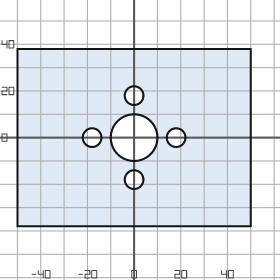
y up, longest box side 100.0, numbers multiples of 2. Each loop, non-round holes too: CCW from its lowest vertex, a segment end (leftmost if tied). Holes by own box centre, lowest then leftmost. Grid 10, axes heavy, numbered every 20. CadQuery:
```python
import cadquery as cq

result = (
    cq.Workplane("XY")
    .moveTo(-50.0, -38.0)
    .lineTo(50.0, -38.0)
    .lineTo(50.0, 38.0)
    .lineTo(-50.0, 38.0)
    .close()
    .moveTo(0.0, -18.0)
    .circle(4.0)
    .moveTo(-18.0, 0.0)
    .circle(4.0)
    .moveTo(0.0, 0.0)
    .circle(10.0)
    .moveTo(18.0, 0.0)
    .circle(4.0)
    .moveTo(0.0, 18.0)
    .circle(4.0)
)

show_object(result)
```